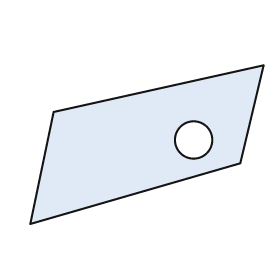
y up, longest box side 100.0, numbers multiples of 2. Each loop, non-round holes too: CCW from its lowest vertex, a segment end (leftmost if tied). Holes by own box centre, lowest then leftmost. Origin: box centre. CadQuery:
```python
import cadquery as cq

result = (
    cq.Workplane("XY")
    .moveTo(-50.0, -34.0)
    .lineTo(40.0, -8.0)
    .lineTo(50.0, 34.0)
    .lineTo(-40.0, 14.0)
    .close()
    .moveTo(20.0, 2.0)
    .circle(8.0)
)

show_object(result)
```